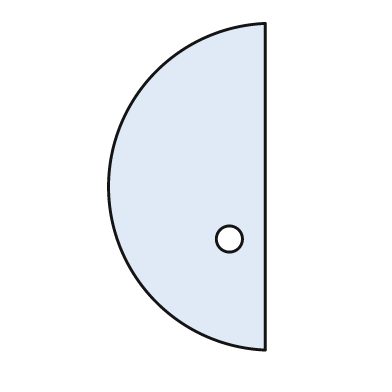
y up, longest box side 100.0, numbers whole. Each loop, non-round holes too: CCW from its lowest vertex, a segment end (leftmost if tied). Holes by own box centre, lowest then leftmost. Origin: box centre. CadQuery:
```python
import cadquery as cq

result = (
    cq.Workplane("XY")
    .moveTo(24.0, -50.0)
    .lineTo(24.0, 50.0)
    .threePointArc((-24.0, 0.0), (24.0, -50.0))
    .close()
    .moveTo(13.0, -16.0)
    .circle(4.0)
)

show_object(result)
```